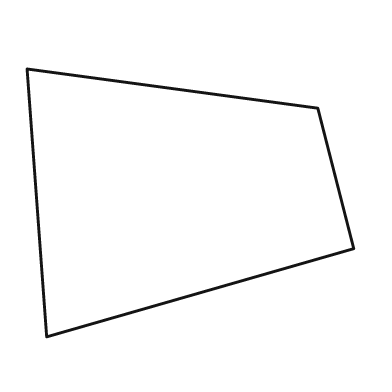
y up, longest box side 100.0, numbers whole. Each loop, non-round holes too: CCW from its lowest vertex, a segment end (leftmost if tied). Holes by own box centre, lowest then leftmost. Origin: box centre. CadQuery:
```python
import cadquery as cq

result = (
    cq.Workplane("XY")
    .moveTo(-44.0, -41.0)
    .lineTo(50.0, -14.0)
    .lineTo(39.0, 29.0)
    .lineTo(-50.0, 41.0)
    .close()
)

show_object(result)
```